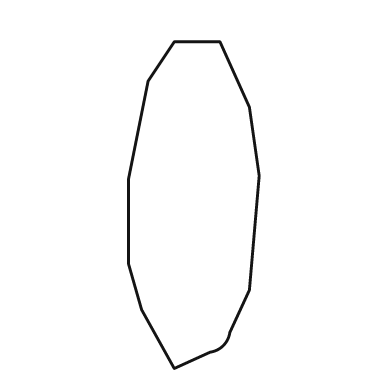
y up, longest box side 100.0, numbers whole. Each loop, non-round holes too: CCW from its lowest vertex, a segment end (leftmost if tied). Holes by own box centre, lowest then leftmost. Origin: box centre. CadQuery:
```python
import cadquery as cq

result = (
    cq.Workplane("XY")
    .moveTo(-6.0, -50.0)
    .lineTo(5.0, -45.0)
    .threePointArc((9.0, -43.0), (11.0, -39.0))
    .lineTo(17.0, -26.0)
    .lineTo(20.0, 9.0)
    .lineTo(17.0, 30.0)
    .lineTo(8.0, 50.0)
    .lineTo(-6.0, 50.0)
    .lineTo(-14.0, 38.0)
    .lineTo(-20.0, 8.0)
    .lineTo(-20.0, -18.0)
    .lineTo(-16.0, -32.0)
    .close()
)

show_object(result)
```